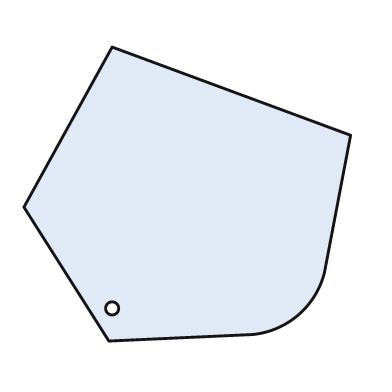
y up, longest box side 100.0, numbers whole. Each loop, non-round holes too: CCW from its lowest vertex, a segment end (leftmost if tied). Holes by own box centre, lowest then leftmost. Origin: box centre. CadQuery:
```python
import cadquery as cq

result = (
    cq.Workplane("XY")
    .moveTo(-24.0, -45.0)
    .lineTo(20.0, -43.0)
    .threePointArc((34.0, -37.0), (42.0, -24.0))
    .lineTo(50.0, 18.0)
    .lineTo(-23.0, 45.0)
    .lineTo(-50.0, -4.0)
    .close()
    .moveTo(-23.0, -35.0)
    .circle(2.0)
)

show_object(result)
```